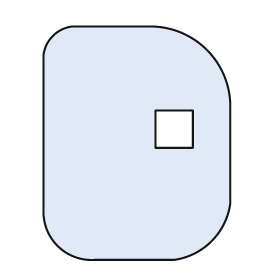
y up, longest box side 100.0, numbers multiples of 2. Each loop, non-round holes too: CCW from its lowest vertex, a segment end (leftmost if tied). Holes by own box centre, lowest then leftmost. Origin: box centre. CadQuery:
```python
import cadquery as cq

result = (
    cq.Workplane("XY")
    .moveTo(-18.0, -50.0)
    .lineTo(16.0, -50.0)
    .threePointArc((32.0, -42.0), (40.0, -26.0))
    .lineTo(40.0, 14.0)
    .threePointArc((30.0, 40.0), (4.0, 50.0))
    .lineTo(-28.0, 50.0)
    .threePointArc((-36.0, 46.0), (-40.0, 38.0))
    .lineTo(-40.0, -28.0)
    .threePointArc((-34.0, -44.0), (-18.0, -50.0))
    .close()
    .moveTo(8.0, -2.0)
    .lineTo(24.0, -2.0)
    .lineTo(24.0, 14.0)
    .lineTo(8.0, 14.0)
    .close()
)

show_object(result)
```